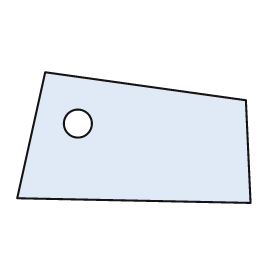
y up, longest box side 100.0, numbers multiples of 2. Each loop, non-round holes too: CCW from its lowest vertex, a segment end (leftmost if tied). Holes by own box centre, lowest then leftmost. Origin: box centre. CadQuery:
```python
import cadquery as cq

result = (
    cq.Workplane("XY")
    .moveTo(50.0, -28.0)
    .lineTo(48.0, 16.0)
    .lineTo(-38.0, 28.0)
    .lineTo(-50.0, -26.0)
    .close()
    .moveTo(-24.0, 6.0)
    .circle(6.0)
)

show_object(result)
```